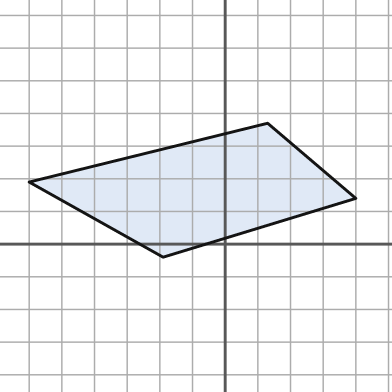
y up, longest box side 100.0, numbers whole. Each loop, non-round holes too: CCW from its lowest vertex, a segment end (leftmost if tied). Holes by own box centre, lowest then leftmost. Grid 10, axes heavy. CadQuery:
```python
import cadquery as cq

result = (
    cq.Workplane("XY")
    .moveTo(-19.0, -4.0)
    .lineTo(40.0, 14.0)
    .lineTo(13.0, 37.0)
    .lineTo(-60.0, 19.0)
    .close()
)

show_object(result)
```